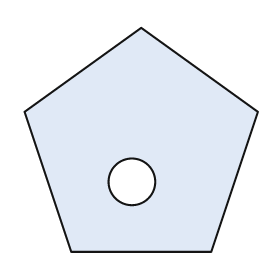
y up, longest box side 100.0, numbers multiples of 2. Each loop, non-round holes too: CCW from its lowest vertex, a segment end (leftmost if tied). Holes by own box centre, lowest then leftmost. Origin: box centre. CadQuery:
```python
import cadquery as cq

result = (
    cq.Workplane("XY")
    .moveTo(-30.0, -48.0)
    .lineTo(30.0, -48.0)
    .lineTo(50.0, 12.0)
    .lineTo(0.0, 48.0)
    .lineTo(-50.0, 12.0)
    .close()
    .moveTo(-4.0, -18.0)
    .circle(10.0)
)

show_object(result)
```